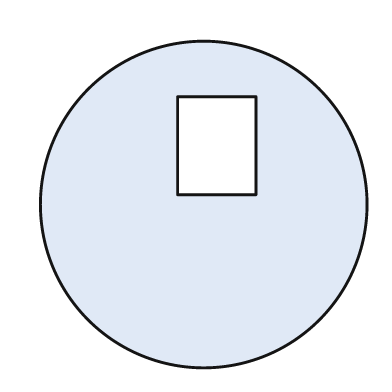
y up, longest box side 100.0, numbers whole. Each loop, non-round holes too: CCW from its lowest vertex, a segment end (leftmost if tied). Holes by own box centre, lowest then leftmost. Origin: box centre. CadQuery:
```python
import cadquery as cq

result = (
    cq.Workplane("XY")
    .moveTo(0.0, 0.0)
    .circle(50.0)
    .moveTo(-8.0, 3.0)
    .lineTo(16.0, 3.0)
    .lineTo(16.0, 33.0)
    .lineTo(-8.0, 33.0)
    .close()
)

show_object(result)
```